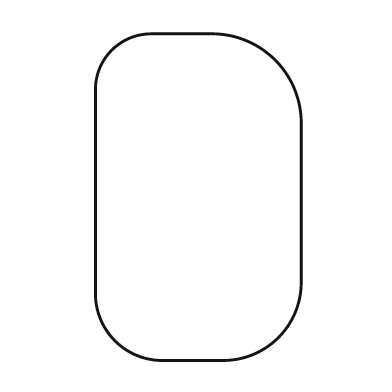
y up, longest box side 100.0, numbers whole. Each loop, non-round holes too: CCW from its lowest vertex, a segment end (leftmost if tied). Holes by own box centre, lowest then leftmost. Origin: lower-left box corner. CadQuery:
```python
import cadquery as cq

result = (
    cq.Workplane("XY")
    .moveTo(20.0, 0.0)
    .lineTo(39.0, 0.0)
    .threePointArc((56.0, 7.0), (63.0, 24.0))
    .lineTo(63.0, 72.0)
    .threePointArc((55.0, 92.0), (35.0, 100.0))
    .lineTo(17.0, 100.0)
    .threePointArc((5.0, 95.0), (0.0, 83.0))
    .lineTo(0.0, 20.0)
    .threePointArc((6.0, 6.0), (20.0, 0.0))
    .close()
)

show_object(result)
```